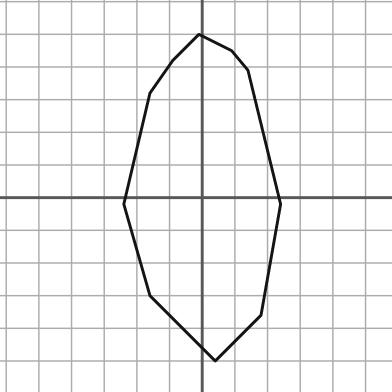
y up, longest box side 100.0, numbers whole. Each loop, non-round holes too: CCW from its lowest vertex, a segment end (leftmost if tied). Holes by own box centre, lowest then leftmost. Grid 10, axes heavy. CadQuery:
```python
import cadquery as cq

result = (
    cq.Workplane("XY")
    .moveTo(4.0, -50.0)
    .lineTo(18.0, -36.0)
    .lineTo(24.0, -2.0)
    .lineTo(14.0, 39.0)
    .lineTo(9.0, 45.0)
    .lineTo(-1.0, 50.0)
    .lineTo(-9.0, 42.0)
    .lineTo(-16.0, 32.0)
    .lineTo(-24.0, -2.0)
    .lineTo(-16.0, -30.0)
    .close()
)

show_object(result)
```